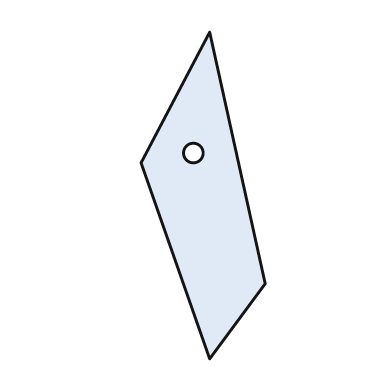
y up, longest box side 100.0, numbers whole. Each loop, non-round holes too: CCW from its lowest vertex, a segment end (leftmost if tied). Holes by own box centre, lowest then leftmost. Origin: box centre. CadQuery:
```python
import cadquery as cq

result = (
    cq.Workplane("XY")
    .moveTo(2.0, -50.0)
    .lineTo(19.0, -27.0)
    .lineTo(2.0, 50.0)
    .lineTo(-19.0, 10.0)
    .close()
    .moveTo(-3.0, 13.0)
    .circle(3.0)
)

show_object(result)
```